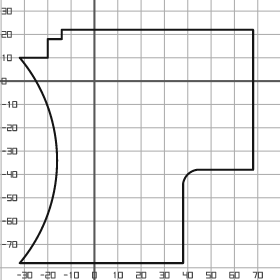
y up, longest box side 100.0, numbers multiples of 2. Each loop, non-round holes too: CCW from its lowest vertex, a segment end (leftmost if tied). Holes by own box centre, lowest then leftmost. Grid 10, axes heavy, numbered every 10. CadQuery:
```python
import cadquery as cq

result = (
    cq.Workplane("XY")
    .moveTo(-32.0, -78.0)
    .lineTo(38.0, -78.0)
    .lineTo(38.0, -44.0)
    .threePointArc((40.0, -40.0), (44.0, -38.0))
    .lineTo(68.0, -38.0)
    .lineTo(68.0, 22.0)
    .lineTo(-14.0, 22.0)
    .lineTo(-14.0, 18.0)
    .lineTo(-20.0, 18.0)
    .lineTo(-20.0, 10.0)
    .lineTo(-32.0, 10.0)
    .threePointArc((-16.0, -34.0), (-32.0, -78.0))
    .close()
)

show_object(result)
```